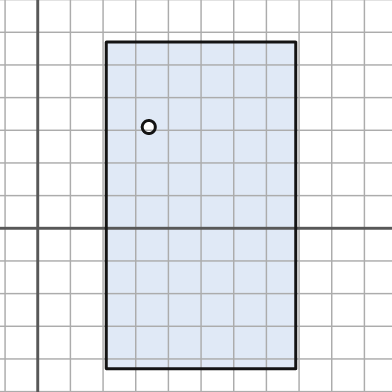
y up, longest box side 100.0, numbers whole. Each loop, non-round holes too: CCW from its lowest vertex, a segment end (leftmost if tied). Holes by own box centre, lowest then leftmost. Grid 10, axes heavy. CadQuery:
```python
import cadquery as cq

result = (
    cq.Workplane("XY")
    .moveTo(21.0, -43.0)
    .lineTo(79.0, -43.0)
    .lineTo(79.0, 57.0)
    .lineTo(21.0, 57.0)
    .close()
    .moveTo(34.0, 31.0)
    .circle(2.0)
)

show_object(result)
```